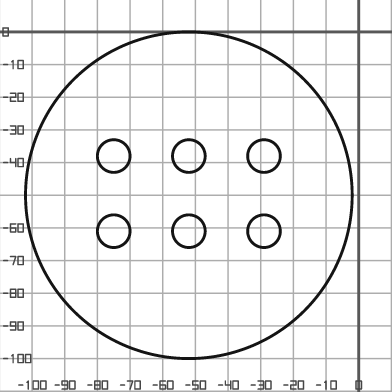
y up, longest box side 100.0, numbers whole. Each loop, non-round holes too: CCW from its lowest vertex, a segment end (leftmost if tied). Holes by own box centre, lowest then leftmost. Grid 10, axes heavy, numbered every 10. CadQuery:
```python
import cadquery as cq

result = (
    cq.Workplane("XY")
    .moveTo(-52.0, -50.0)
    .circle(50.0)
    .moveTo(-75.0, -61.0)
    .circle(5.0)
    .moveTo(-52.0, -61.0)
    .circle(5.0)
    .moveTo(-29.0, -61.0)
    .circle(5.0)
    .moveTo(-75.0, -38.0)
    .circle(5.0)
    .moveTo(-52.0, -38.0)
    .circle(5.0)
    .moveTo(-29.0, -38.0)
    .circle(5.0)
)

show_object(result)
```